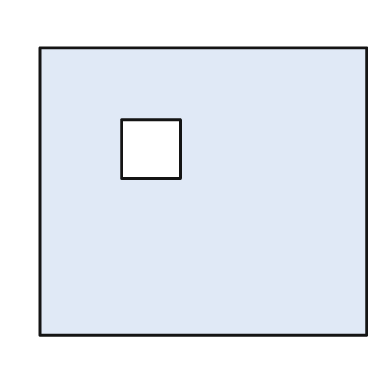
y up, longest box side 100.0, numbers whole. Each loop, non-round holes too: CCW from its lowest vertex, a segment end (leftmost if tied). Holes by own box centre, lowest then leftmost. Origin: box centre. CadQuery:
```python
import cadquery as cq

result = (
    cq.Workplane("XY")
    .moveTo(-50.0, -44.0)
    .lineTo(50.0, -44.0)
    .lineTo(50.0, 44.0)
    .lineTo(-50.0, 44.0)
    .close()
    .moveTo(-25.0, 4.0)
    .lineTo(-7.0, 4.0)
    .lineTo(-7.0, 22.0)
    .lineTo(-25.0, 22.0)
    .close()
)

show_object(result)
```